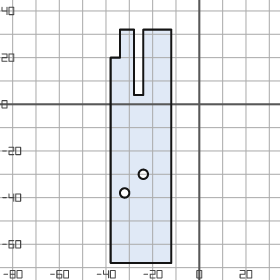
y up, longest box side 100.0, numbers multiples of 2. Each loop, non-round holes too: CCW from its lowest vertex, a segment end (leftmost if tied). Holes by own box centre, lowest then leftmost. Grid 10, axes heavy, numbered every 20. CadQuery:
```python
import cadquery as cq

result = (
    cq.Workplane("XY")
    .moveTo(-38.0, -68.0)
    .lineTo(-12.0, -68.0)
    .lineTo(-12.0, 32.0)
    .lineTo(-24.0, 32.0)
    .lineTo(-24.0, 4.0)
    .lineTo(-28.0, 4.0)
    .lineTo(-28.0, 32.0)
    .lineTo(-34.0, 32.0)
    .lineTo(-34.0, 20.0)
    .lineTo(-38.0, 20.0)
    .close()
    .moveTo(-32.0, -38.0)
    .circle(2.0)
    .moveTo(-24.0, -30.0)
    .circle(2.0)
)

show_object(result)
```